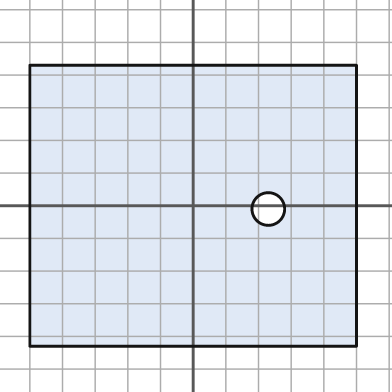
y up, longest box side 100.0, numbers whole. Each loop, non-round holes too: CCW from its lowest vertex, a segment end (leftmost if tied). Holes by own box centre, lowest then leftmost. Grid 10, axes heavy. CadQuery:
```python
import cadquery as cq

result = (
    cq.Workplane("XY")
    .moveTo(-50.0, -43.0)
    .lineTo(50.0, -43.0)
    .lineTo(50.0, 43.0)
    .lineTo(-50.0, 43.0)
    .close()
    .moveTo(23.0, -1.0)
    .circle(5.0)
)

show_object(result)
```